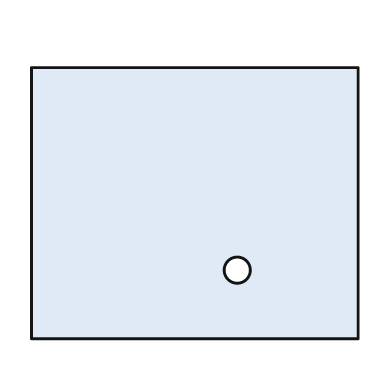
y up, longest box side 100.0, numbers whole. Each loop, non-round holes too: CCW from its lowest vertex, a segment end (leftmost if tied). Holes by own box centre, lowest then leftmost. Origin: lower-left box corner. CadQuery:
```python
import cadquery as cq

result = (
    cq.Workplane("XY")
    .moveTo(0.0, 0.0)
    .lineTo(100.0, 0.0)
    .lineTo(100.0, 83.0)
    .lineTo(0.0, 83.0)
    .close()
    .moveTo(63.0, 21.0)
    .circle(4.0)
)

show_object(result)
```